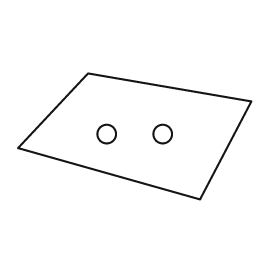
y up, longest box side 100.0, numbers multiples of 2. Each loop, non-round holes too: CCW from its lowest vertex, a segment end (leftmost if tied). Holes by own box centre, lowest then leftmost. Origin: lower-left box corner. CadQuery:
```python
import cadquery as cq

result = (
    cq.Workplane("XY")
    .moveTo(78.0, 0.0)
    .lineTo(100.0, 42.0)
    .lineTo(30.0, 54.0)
    .lineTo(0.0, 22.0)
    .close()
    .moveTo(38.0, 28.0)
    .circle(4.0)
    .moveTo(62.0, 28.0)
    .circle(4.0)
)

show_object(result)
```